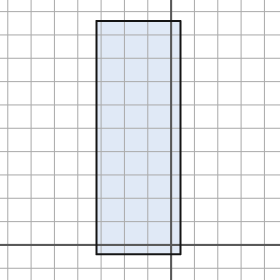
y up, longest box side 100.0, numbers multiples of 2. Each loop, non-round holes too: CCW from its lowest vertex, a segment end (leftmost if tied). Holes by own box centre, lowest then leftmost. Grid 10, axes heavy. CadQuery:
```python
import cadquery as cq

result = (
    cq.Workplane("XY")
    .moveTo(-32.0, -4.0)
    .lineTo(4.0, -4.0)
    .lineTo(4.0, 96.0)
    .lineTo(-32.0, 96.0)
    .close()
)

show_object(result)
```